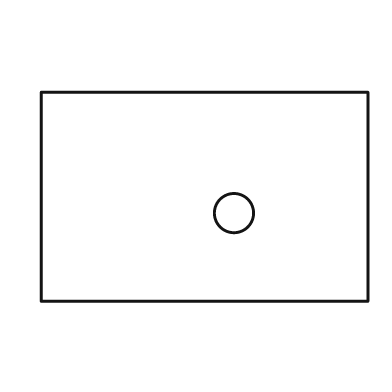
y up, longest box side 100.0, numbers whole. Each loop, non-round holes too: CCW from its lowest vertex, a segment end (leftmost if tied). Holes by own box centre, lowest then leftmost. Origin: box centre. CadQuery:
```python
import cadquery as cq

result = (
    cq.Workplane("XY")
    .moveTo(-50.0, -32.0)
    .lineTo(50.0, -32.0)
    .lineTo(50.0, 32.0)
    .lineTo(-50.0, 32.0)
    .close()
    .moveTo(9.0, -5.0)
    .circle(6.0)
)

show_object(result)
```